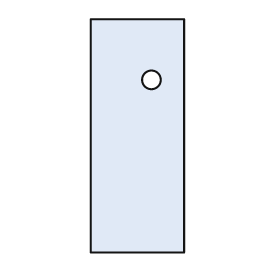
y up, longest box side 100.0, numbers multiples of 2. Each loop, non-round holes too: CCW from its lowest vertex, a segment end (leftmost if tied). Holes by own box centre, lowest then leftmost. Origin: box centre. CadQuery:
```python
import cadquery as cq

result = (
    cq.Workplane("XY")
    .moveTo(-20.0, -50.0)
    .lineTo(20.0, -50.0)
    .lineTo(20.0, 50.0)
    .lineTo(-20.0, 50.0)
    .close()
    .moveTo(6.0, 24.0)
    .circle(4.0)
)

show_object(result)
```